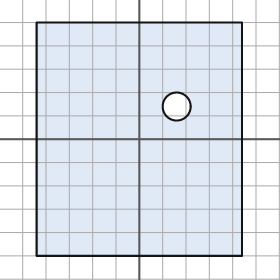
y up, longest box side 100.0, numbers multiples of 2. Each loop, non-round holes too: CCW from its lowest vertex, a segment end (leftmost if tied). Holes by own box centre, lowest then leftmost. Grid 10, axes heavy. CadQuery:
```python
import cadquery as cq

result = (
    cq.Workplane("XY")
    .moveTo(-44.0, -50.0)
    .lineTo(44.0, -50.0)
    .lineTo(44.0, 50.0)
    .lineTo(-44.0, 50.0)
    .close()
    .moveTo(16.0, 14.0)
    .circle(6.0)
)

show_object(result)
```